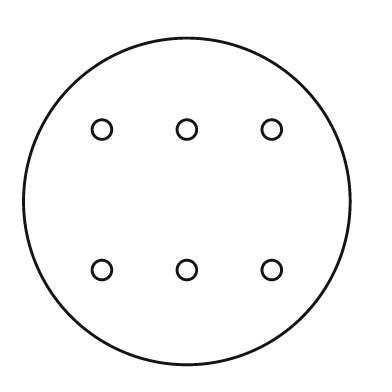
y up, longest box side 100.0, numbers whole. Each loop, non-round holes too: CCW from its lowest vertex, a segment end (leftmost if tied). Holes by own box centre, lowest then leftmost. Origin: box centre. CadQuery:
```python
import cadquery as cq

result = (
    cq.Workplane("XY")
    .moveTo(0.0, 0.0)
    .circle(50.0)
    .moveTo(-26.0, -21.0)
    .circle(3.0)
    .moveTo(0.0, -21.0)
    .circle(3.0)
    .moveTo(26.0, -21.0)
    .circle(3.0)
    .moveTo(-26.0, 22.0)
    .circle(3.0)
    .moveTo(0.0, 22.0)
    .circle(3.0)
    .moveTo(26.0, 22.0)
    .circle(3.0)
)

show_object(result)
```